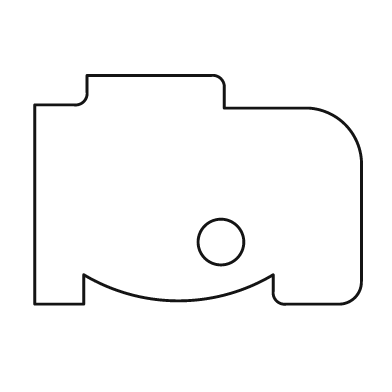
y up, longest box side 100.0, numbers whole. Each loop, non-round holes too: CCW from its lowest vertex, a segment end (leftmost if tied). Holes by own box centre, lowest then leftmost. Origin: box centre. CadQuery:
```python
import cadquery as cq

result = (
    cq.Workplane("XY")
    .moveTo(-50.0, -35.0)
    .lineTo(-35.0, -35.0)
    .lineTo(-35.0, -26.0)
    .threePointArc((-6.0, -34.0), (23.0, -26.0))
    .lineTo(23.0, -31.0)
    .threePointArc((24.0, -34.0), (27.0, -35.0))
    .lineTo(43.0, -35.0)
    .threePointArc((48.0, -33.0), (50.0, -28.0))
    .lineTo(50.0, 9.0)
    .threePointArc((45.0, 20.0), (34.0, 25.0))
    .lineTo(8.0, 25.0)
    .lineTo(8.0, 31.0)
    .threePointArc((7.0, 34.0), (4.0, 35.0))
    .lineTo(-34.0, 35.0)
    .lineTo(-34.0, 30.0)
    .threePointArc((-35.0, 27.0), (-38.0, 26.0))
    .lineTo(-50.0, 26.0)
    .close()
    .moveTo(7.0, -16.0)
    .circle(7.0)
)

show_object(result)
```